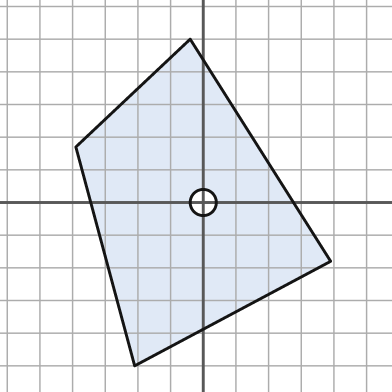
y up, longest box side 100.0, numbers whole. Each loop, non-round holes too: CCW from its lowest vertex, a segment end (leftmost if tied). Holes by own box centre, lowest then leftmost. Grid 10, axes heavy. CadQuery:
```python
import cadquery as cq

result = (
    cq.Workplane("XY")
    .moveTo(-21.0, -50.0)
    .lineTo(39.0, -18.0)
    .lineTo(-4.0, 50.0)
    .lineTo(-39.0, 17.0)
    .close()
    .moveTo(0.0, 0.0)
    .circle(4.0)
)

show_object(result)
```